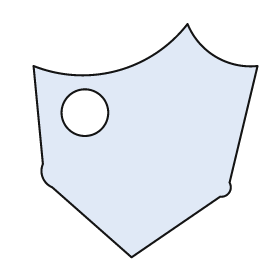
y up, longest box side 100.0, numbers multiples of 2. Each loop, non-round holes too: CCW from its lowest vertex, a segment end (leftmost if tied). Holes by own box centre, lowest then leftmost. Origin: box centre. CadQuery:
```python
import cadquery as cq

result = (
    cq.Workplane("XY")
    .moveTo(-6.0, -50.0)
    .lineTo(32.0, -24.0)
    .threePointArc((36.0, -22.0), (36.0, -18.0))
    .lineTo(48.0, 32.0)
    .threePointArc((30.0, 36.0), (18.0, 50.0))
    .threePointArc((-12.0, 30.0), (-48.0, 32.0))
    .lineTo(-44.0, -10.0)
    .threePointArc((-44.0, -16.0), (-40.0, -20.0))
    .close()
    .moveTo(-26.0, 12.0)
    .circle(10.0)
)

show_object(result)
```